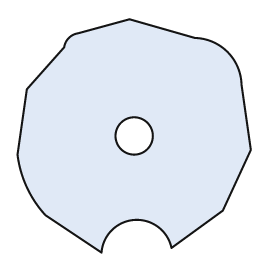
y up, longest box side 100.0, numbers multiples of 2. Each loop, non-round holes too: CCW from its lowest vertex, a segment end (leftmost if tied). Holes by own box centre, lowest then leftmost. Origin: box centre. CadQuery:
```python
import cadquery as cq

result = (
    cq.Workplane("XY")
    .moveTo(-14.0, -50.0)
    .threePointArc((0.0, -36.0), (16.0, -48.0))
    .lineTo(38.0, -32.0)
    .lineTo(50.0, -6.0)
    .lineTo(46.0, 22.0)
    .threePointArc((40.0, 36.0), (26.0, 42.0))
    .lineTo(-2.0, 50.0)
    .lineTo(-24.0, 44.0)
    .threePointArc((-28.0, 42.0), (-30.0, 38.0))
    .lineTo(-46.0, 20.0)
    .lineTo(-50.0, -8.0)
    .threePointArc((-46.0, -22.0), (-38.0, -34.0))
    .close()
    .moveTo(0.0, 0.0)
    .circle(8.0)
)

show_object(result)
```